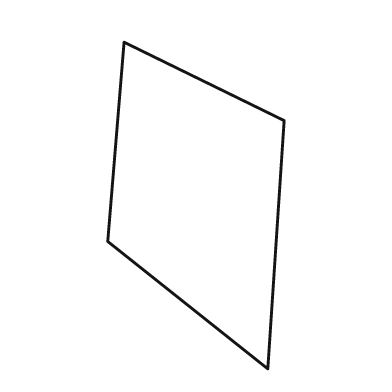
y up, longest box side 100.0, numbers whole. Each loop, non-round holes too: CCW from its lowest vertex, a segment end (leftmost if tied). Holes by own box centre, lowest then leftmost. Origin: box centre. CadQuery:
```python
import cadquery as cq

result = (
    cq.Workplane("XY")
    .moveTo(22.0, -50.0)
    .lineTo(27.0, 26.0)
    .lineTo(-22.0, 50.0)
    .lineTo(-27.0, -11.0)
    .close()
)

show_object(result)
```